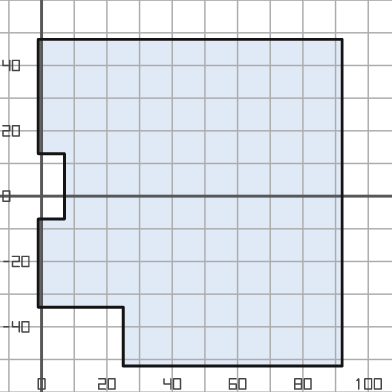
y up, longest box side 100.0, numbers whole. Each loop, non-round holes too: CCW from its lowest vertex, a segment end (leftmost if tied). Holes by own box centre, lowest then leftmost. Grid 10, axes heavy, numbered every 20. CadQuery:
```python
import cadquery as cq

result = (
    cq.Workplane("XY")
    .moveTo(25.0, -52.0)
    .lineTo(92.0, -52.0)
    .lineTo(92.0, 48.0)
    .lineTo(-1.0, 48.0)
    .lineTo(-1.0, 13.0)
    .lineTo(7.0, 13.0)
    .lineTo(7.0, -7.0)
    .lineTo(-1.0, -7.0)
    .lineTo(-1.0, -34.0)
    .lineTo(25.0, -34.0)
    .close()
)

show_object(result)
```